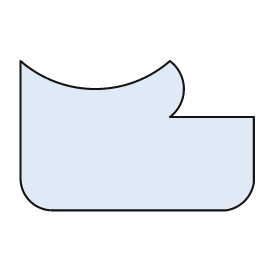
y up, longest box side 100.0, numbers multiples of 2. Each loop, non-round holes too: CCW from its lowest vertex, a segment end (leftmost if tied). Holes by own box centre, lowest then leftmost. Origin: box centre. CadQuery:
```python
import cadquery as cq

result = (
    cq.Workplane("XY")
    .moveTo(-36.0, -32.0)
    .lineTo(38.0, -32.0)
    .threePointArc((46.0, -28.0), (50.0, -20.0))
    .lineTo(50.0, 8.0)
    .lineTo(14.0, 8.0)
    .threePointArc((20.0, 20.0), (14.0, 32.0))
    .threePointArc((-18.0, 20.0), (-50.0, 32.0))
    .lineTo(-50.0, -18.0)
    .threePointArc((-46.0, -28.0), (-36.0, -32.0))
    .close()
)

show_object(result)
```